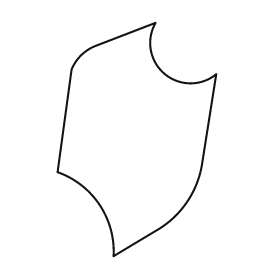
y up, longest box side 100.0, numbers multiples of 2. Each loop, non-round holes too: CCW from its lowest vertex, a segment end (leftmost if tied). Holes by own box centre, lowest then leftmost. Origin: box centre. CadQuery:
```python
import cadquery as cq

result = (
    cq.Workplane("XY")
    .moveTo(-10.0, -50.0)
    .lineTo(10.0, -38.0)
    .threePointArc((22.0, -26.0), (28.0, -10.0))
    .lineTo(34.0, 28.0)
    .threePointArc((12.0, 28.0), (8.0, 50.0))
    .lineTo(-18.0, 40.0)
    .threePointArc((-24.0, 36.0), (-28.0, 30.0))
    .lineTo(-34.0, -14.0)
    .threePointArc((-16.0, -28.0), (-10.0, -50.0))
    .close()
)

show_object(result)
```